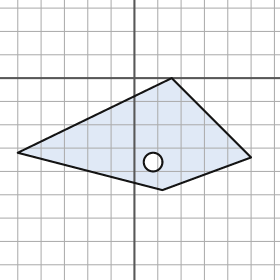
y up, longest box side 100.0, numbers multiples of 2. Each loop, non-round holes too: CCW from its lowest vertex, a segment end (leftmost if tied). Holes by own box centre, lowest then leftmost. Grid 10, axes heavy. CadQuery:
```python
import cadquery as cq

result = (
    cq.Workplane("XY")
    .moveTo(12.0, -48.0)
    .lineTo(50.0, -34.0)
    .lineTo(16.0, 0.0)
    .lineTo(-50.0, -32.0)
    .close()
    .moveTo(8.0, -36.0)
    .circle(4.0)
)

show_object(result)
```